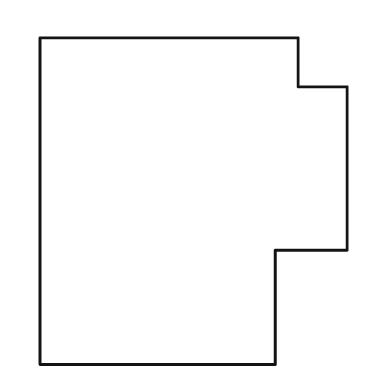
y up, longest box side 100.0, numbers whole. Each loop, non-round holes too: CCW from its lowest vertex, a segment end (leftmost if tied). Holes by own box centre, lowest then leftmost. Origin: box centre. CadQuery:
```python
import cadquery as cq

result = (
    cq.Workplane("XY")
    .moveTo(-47.0, -50.0)
    .lineTo(25.0, -50.0)
    .lineTo(25.0, -15.0)
    .lineTo(47.0, -15.0)
    .lineTo(47.0, 35.0)
    .lineTo(32.0, 35.0)
    .lineTo(32.0, 50.0)
    .lineTo(-47.0, 50.0)
    .close()
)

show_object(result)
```